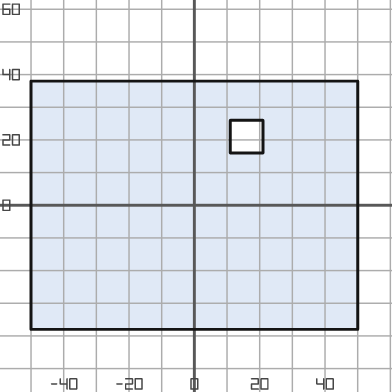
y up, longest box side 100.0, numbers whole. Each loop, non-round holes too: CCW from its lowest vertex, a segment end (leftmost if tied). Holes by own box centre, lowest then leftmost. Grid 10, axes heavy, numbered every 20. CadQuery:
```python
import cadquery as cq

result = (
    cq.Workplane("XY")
    .moveTo(-50.0, -38.0)
    .lineTo(50.0, -38.0)
    .lineTo(50.0, 38.0)
    .lineTo(-50.0, 38.0)
    .close()
    .moveTo(11.0, 16.0)
    .lineTo(21.0, 16.0)
    .lineTo(21.0, 26.0)
    .lineTo(11.0, 26.0)
    .close()
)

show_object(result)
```